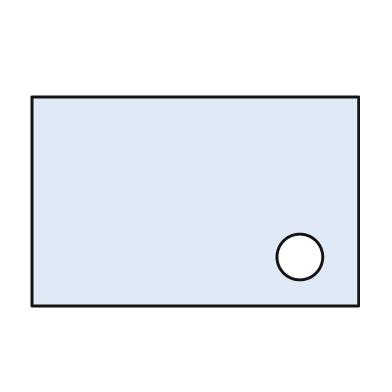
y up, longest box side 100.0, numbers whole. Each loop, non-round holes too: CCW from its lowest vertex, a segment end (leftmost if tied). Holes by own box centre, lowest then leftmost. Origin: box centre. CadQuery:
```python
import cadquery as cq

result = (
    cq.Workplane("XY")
    .moveTo(-50.0, -32.0)
    .lineTo(50.0, -32.0)
    .lineTo(50.0, 32.0)
    .lineTo(-50.0, 32.0)
    .close()
    .moveTo(32.0, -17.0)
    .circle(7.0)
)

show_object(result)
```